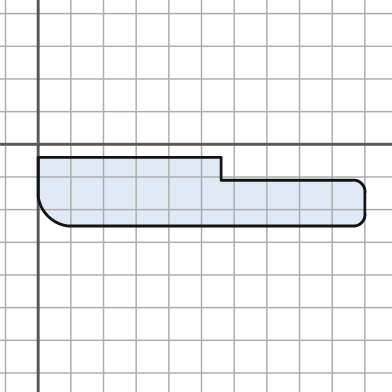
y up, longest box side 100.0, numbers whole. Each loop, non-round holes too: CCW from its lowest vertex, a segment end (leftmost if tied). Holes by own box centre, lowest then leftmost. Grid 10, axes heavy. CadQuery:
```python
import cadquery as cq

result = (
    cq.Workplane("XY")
    .moveTo(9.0, -25.0)
    .lineTo(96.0, -25.0)
    .threePointArc((99.0, -24.0), (100.0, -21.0))
    .lineTo(100.0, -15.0)
    .threePointArc((99.0, -12.0), (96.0, -11.0))
    .lineTo(56.0, -11.0)
    .lineTo(56.0, -4.0)
    .lineTo(0.0, -4.0)
    .lineTo(0.0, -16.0)
    .threePointArc((3.0, -22.0), (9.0, -25.0))
    .close()
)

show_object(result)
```